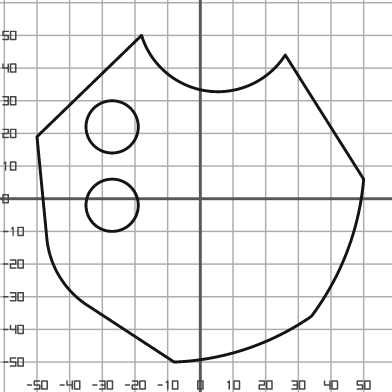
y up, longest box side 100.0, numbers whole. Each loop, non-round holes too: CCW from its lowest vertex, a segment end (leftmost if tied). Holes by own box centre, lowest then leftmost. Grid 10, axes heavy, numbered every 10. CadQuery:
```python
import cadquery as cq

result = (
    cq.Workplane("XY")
    .moveTo(-8.0, -50.0)
    .threePointArc((14.0, -46.0), (34.0, -36.0))
    .threePointArc((45.0, -16.0), (50.0, 6.0))
    .lineTo(26.0, 44.0)
    .threePointArc((2.0, 33.0), (-18.0, 50.0))
    .lineTo(-50.0, 19.0)
    .lineTo(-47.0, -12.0)
    .threePointArc((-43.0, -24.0), (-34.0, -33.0))
    .close()
    .moveTo(-27.0, -2.0)
    .circle(8.0)
    .moveTo(-27.0, 22.0)
    .circle(8.0)
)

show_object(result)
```